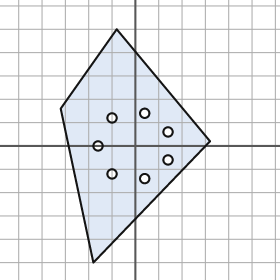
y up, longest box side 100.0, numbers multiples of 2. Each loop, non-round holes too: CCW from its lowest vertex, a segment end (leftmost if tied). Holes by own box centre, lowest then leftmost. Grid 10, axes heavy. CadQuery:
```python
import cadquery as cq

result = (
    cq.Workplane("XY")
    .moveTo(-18.0, -50.0)
    .lineTo(32.0, 2.0)
    .lineTo(-8.0, 50.0)
    .lineTo(-32.0, 16.0)
    .close()
    .moveTo(4.0, -14.0)
    .circle(2.0)
    .moveTo(-10.0, -12.0)
    .circle(2.0)
    .moveTo(14.0, -6.0)
    .circle(2.0)
    .moveTo(-16.0, 0.0)
    .circle(2.0)
    .moveTo(14.0, 6.0)
    .circle(2.0)
    .moveTo(-10.0, 12.0)
    .circle(2.0)
    .moveTo(4.0, 14.0)
    .circle(2.0)
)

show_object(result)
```